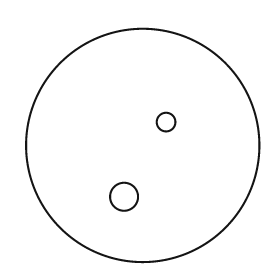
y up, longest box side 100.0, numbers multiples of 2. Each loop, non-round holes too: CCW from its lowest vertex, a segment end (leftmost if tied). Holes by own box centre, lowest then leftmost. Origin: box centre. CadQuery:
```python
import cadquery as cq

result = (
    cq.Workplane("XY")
    .moveTo(0.0, 0.0)
    .circle(50.0)
    .moveTo(-8.0, -22.0)
    .circle(6.0)
    .moveTo(10.0, 10.0)
    .circle(4.0)
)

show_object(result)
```